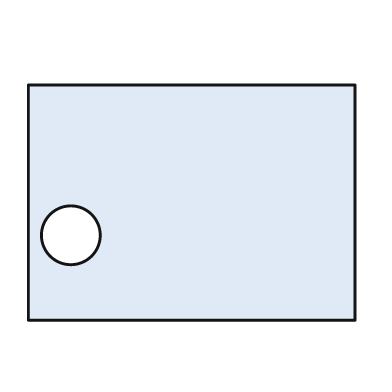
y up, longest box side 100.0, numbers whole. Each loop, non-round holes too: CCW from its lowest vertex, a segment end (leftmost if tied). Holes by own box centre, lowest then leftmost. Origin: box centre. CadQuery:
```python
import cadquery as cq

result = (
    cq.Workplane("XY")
    .moveTo(-50.0, -36.0)
    .lineTo(50.0, -36.0)
    .lineTo(50.0, 36.0)
    .lineTo(-50.0, 36.0)
    .close()
    .moveTo(-37.0, -10.0)
    .circle(9.0)
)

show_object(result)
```